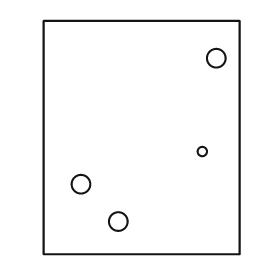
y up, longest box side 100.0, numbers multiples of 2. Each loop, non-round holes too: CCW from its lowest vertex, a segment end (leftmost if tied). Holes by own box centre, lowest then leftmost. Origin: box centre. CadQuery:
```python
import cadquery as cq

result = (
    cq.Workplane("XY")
    .moveTo(-42.0, -50.0)
    .lineTo(42.0, -50.0)
    .lineTo(42.0, 50.0)
    .lineTo(-42.0, 50.0)
    .close()
    .moveTo(-10.0, -36.0)
    .circle(4.0)
    .moveTo(-26.0, -20.0)
    .circle(4.0)
    .moveTo(26.0, -6.0)
    .circle(2.0)
    .moveTo(32.0, 34.0)
    .circle(4.0)
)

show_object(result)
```